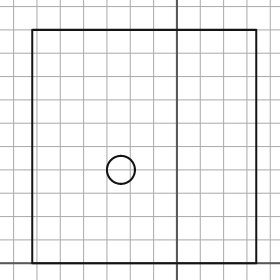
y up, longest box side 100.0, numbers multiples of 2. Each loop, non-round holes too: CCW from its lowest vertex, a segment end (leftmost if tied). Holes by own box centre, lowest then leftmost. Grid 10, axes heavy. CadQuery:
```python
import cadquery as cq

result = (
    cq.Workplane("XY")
    .moveTo(-62.0, 0.0)
    .lineTo(34.0, 0.0)
    .lineTo(34.0, 100.0)
    .lineTo(-62.0, 100.0)
    .close()
    .moveTo(-24.0, 40.0)
    .circle(6.0)
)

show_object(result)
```